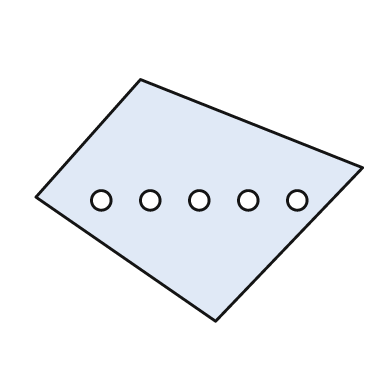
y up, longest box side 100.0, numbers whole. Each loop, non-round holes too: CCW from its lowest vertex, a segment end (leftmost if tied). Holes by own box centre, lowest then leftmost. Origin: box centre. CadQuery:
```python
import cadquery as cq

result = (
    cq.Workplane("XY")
    .moveTo(5.0, -37.0)
    .lineTo(50.0, 10.0)
    .lineTo(-18.0, 37.0)
    .lineTo(-50.0, 1.0)
    .close()
    .moveTo(-30.0, 0.0)
    .circle(3.0)
    .moveTo(-15.0, 0.0)
    .circle(3.0)
    .moveTo(0.0, 0.0)
    .circle(3.0)
    .moveTo(15.0, 0.0)
    .circle(3.0)
    .moveTo(30.0, 0.0)
    .circle(3.0)
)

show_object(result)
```